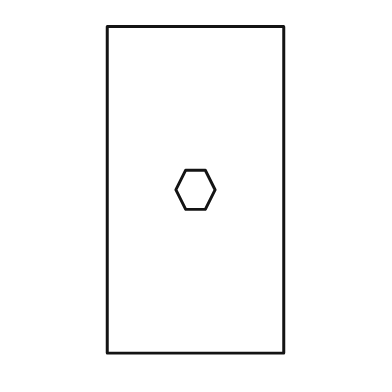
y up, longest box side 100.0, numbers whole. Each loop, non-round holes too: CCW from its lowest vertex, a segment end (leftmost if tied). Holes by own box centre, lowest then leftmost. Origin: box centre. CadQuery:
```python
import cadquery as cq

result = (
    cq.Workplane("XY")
    .moveTo(-27.0, -50.0)
    .lineTo(27.0, -50.0)
    .lineTo(27.0, 50.0)
    .lineTo(-27.0, 50.0)
    .close()
    .moveTo(-3.0, -6.0)
    .lineTo(3.0, -6.0)
    .lineTo(6.0, 0.0)
    .lineTo(3.0, 6.0)
    .lineTo(-3.0, 6.0)
    .lineTo(-6.0, 0.0)
    .close()
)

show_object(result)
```